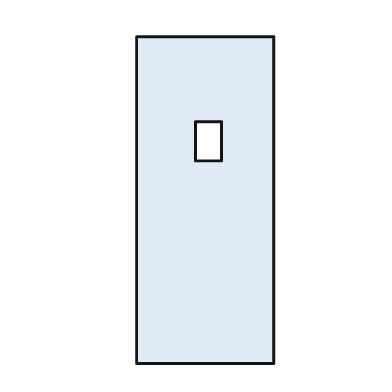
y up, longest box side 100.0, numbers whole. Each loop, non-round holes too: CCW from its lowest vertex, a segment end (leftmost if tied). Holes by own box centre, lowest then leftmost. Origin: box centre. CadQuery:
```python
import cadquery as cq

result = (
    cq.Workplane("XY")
    .moveTo(-21.0, -50.0)
    .lineTo(21.0, -50.0)
    .lineTo(21.0, 50.0)
    .lineTo(-21.0, 50.0)
    .close()
    .moveTo(-3.0, 12.0)
    .lineTo(5.0, 12.0)
    .lineTo(5.0, 24.0)
    .lineTo(-3.0, 24.0)
    .close()
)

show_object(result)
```